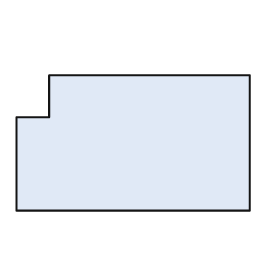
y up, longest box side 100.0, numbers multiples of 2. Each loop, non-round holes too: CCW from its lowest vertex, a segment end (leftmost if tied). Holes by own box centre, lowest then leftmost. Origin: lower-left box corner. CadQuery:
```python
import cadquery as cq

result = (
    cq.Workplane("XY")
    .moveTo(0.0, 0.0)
    .lineTo(100.0, 0.0)
    .lineTo(100.0, 58.0)
    .lineTo(14.0, 58.0)
    .lineTo(14.0, 40.0)
    .lineTo(0.0, 40.0)
    .close()
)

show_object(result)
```